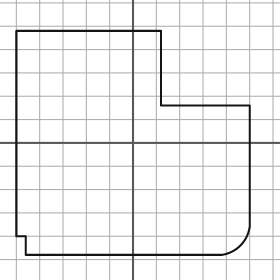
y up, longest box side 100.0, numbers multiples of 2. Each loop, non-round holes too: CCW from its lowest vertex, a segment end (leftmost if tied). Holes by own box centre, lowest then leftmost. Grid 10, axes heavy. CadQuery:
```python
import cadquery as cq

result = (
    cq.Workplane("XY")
    .moveTo(-46.0, -48.0)
    .lineTo(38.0, -48.0)
    .threePointArc((46.0, -44.0), (50.0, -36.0))
    .lineTo(50.0, 16.0)
    .lineTo(12.0, 16.0)
    .lineTo(12.0, 48.0)
    .lineTo(-50.0, 48.0)
    .lineTo(-50.0, -40.0)
    .lineTo(-46.0, -40.0)
    .close()
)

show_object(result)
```